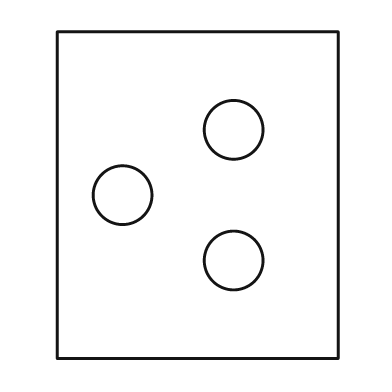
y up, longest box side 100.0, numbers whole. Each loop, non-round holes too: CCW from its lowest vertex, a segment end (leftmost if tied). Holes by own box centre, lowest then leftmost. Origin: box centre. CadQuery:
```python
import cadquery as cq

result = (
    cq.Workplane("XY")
    .moveTo(-43.0, -50.0)
    .lineTo(43.0, -50.0)
    .lineTo(43.0, 50.0)
    .lineTo(-43.0, 50.0)
    .close()
    .moveTo(11.0, -20.0)
    .circle(9.0)
    .moveTo(-23.0, 0.0)
    .circle(9.0)
    .moveTo(11.0, 20.0)
    .circle(9.0)
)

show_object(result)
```